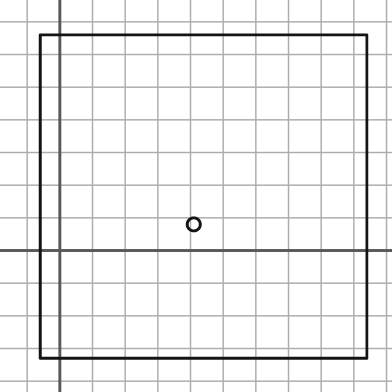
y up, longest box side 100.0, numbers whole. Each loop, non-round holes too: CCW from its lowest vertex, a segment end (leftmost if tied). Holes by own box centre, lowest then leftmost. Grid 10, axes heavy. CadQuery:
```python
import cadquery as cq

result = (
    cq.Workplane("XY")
    .moveTo(-6.0, -33.0)
    .lineTo(94.0, -33.0)
    .lineTo(94.0, 66.0)
    .lineTo(-6.0, 66.0)
    .close()
    .moveTo(41.0, 8.0)
    .circle(2.0)
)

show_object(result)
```